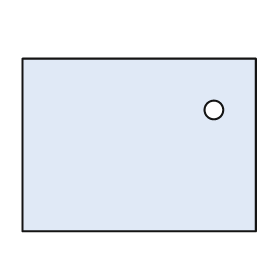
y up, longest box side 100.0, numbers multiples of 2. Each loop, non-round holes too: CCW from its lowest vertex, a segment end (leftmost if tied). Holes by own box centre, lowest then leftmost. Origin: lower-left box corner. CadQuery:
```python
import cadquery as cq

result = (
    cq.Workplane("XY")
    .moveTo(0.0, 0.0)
    .lineTo(100.0, 0.0)
    .lineTo(100.0, 74.0)
    .lineTo(0.0, 74.0)
    .close()
    .moveTo(82.0, 52.0)
    .circle(4.0)
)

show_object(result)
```